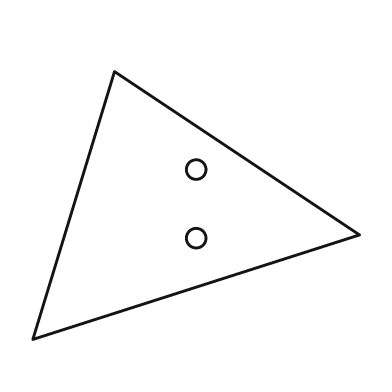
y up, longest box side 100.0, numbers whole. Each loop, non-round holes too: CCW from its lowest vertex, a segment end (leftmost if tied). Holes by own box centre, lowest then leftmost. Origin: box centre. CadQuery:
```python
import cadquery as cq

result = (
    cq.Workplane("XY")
    .moveTo(-50.0, -41.0)
    .lineTo(50.0, -9.0)
    .lineTo(-25.0, 41.0)
    .close()
    .moveTo(0.0, -10.0)
    .circle(3.0)
    .moveTo(0.0, 11.0)
    .circle(3.0)
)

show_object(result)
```